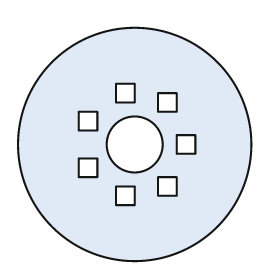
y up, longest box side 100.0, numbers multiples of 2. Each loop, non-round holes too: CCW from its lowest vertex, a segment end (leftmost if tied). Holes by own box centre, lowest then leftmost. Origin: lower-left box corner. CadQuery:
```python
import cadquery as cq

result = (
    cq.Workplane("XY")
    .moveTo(50.0, 50.0)
    .circle(50.0)
    .moveTo(42.0, 24.0)
    .lineTo(50.0, 24.0)
    .lineTo(50.0, 32.0)
    .lineTo(42.0, 32.0)
    .close()
    .moveTo(60.0, 28.0)
    .lineTo(68.0, 28.0)
    .lineTo(68.0, 36.0)
    .lineTo(60.0, 36.0)
    .close()
    .moveTo(26.0, 36.0)
    .lineTo(34.0, 36.0)
    .lineTo(34.0, 44.0)
    .lineTo(26.0, 44.0)
    .close()
    .moveTo(50.0, 50.0)
    .circle(12.0)
    .moveTo(68.0, 46.0)
    .lineTo(76.0, 46.0)
    .lineTo(76.0, 54.0)
    .lineTo(68.0, 54.0)
    .close()
    .moveTo(26.0, 56.0)
    .lineTo(34.0, 56.0)
    .lineTo(34.0, 64.0)
    .lineTo(26.0, 64.0)
    .close()
    .moveTo(60.0, 64.0)
    .lineTo(68.0, 64.0)
    .lineTo(68.0, 72.0)
    .lineTo(60.0, 72.0)
    .close()
    .moveTo(42.0, 68.0)
    .lineTo(50.0, 68.0)
    .lineTo(50.0, 76.0)
    .lineTo(42.0, 76.0)
    .close()
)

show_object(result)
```